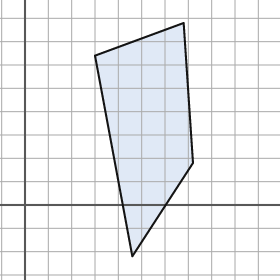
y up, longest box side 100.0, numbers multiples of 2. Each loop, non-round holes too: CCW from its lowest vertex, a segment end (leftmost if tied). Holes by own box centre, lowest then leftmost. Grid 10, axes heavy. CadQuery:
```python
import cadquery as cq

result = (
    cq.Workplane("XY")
    .moveTo(46.0, -22.0)
    .lineTo(72.0, 18.0)
    .lineTo(68.0, 78.0)
    .lineTo(30.0, 64.0)
    .close()
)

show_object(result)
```